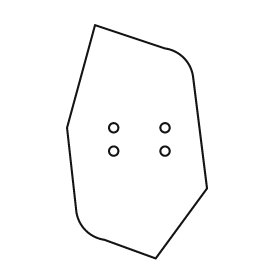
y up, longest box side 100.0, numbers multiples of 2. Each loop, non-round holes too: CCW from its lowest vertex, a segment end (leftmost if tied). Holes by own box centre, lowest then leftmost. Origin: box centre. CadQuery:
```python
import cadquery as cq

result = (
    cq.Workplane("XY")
    .moveTo(8.0, -50.0)
    .lineTo(30.0, -20.0)
    .lineTo(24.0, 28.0)
    .threePointArc((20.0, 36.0), (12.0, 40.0))
    .lineTo(-18.0, 50.0)
    .lineTo(-30.0, 6.0)
    .lineTo(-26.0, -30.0)
    .threePointArc((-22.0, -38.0), (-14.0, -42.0))
    .close()
    .moveTo(-10.0, -4.0)
    .circle(2.0)
    .moveTo(12.0, -4.0)
    .circle(2.0)
    .moveTo(-10.0, 6.0)
    .circle(2.0)
    .moveTo(12.0, 6.0)
    .circle(2.0)
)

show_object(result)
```